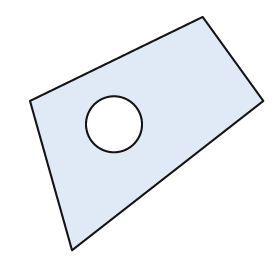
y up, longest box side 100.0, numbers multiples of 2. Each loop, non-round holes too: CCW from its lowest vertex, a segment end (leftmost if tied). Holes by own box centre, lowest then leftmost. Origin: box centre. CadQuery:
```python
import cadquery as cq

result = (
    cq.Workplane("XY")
    .moveTo(-32.0, -50.0)
    .lineTo(50.0, 14.0)
    .lineTo(24.0, 50.0)
    .lineTo(-50.0, 14.0)
    .close()
    .moveTo(-14.0, 4.0)
    .circle(12.0)
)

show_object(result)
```